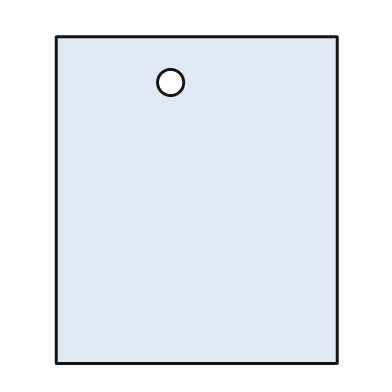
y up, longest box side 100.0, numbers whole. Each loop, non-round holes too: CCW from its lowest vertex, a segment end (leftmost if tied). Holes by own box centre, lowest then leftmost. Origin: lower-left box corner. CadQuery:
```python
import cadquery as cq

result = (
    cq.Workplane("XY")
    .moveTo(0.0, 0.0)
    .lineTo(86.0, 0.0)
    .lineTo(86.0, 100.0)
    .lineTo(0.0, 100.0)
    .close()
    .moveTo(35.0, 86.0)
    .circle(4.0)
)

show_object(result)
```